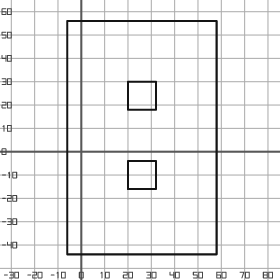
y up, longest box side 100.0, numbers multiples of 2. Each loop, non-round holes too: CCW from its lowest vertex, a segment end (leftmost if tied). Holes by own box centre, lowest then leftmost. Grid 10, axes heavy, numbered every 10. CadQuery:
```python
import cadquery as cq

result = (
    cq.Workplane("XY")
    .moveTo(-6.0, -44.0)
    .lineTo(58.0, -44.0)
    .lineTo(58.0, 56.0)
    .lineTo(-6.0, 56.0)
    .close()
    .moveTo(20.0, -16.0)
    .lineTo(32.0, -16.0)
    .lineTo(32.0, -4.0)
    .lineTo(20.0, -4.0)
    .close()
    .moveTo(20.0, 18.0)
    .lineTo(32.0, 18.0)
    .lineTo(32.0, 30.0)
    .lineTo(20.0, 30.0)
    .close()
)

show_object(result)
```